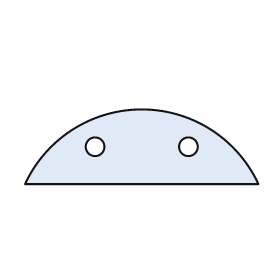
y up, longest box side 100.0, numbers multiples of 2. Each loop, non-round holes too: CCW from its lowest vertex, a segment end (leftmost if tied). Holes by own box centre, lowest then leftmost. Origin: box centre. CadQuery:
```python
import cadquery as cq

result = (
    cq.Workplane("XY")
    .moveTo(-50.0, -16.0)
    .lineTo(50.0, -16.0)
    .threePointArc((0.0, 16.0), (-50.0, -16.0))
    .close()
    .moveTo(-20.0, 0.0)
    .circle(4.0)
    .moveTo(20.0, 0.0)
    .circle(4.0)
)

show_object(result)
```